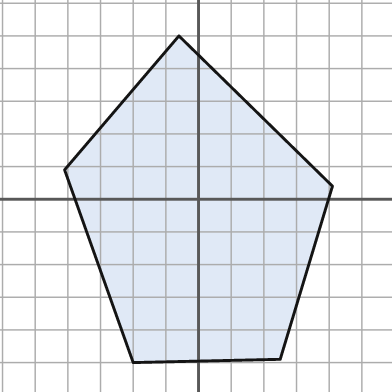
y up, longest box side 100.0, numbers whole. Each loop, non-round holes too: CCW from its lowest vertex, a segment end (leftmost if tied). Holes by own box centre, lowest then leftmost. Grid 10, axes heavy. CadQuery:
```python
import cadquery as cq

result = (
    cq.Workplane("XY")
    .moveTo(-20.0, -50.0)
    .lineTo(25.0, -49.0)
    .lineTo(41.0, 4.0)
    .lineTo(-6.0, 50.0)
    .lineTo(-41.0, 9.0)
    .close()
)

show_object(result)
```